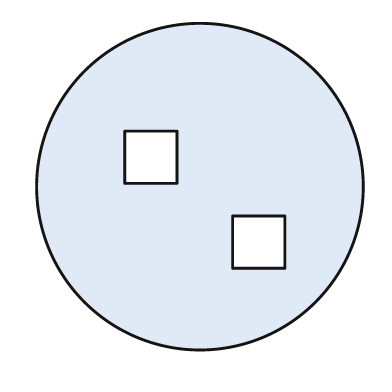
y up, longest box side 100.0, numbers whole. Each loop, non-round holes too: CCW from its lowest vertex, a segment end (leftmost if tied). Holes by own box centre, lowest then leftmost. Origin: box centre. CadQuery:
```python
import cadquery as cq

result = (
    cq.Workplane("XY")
    .moveTo(0.0, 0.0)
    .circle(50.0)
    .moveTo(10.0, -25.0)
    .lineTo(26.0, -25.0)
    .lineTo(26.0, -9.0)
    .lineTo(10.0, -9.0)
    .close()
    .moveTo(-23.0, 1.0)
    .lineTo(-7.0, 1.0)
    .lineTo(-7.0, 17.0)
    .lineTo(-23.0, 17.0)
    .close()
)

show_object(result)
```